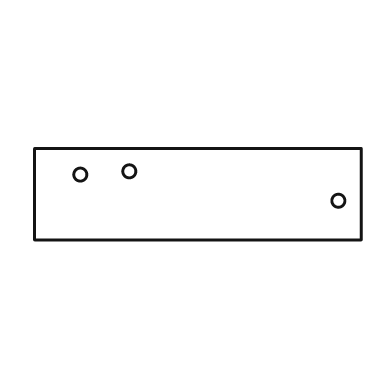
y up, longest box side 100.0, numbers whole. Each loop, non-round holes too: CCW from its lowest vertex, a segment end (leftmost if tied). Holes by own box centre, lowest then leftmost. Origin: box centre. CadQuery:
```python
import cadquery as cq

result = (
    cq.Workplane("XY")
    .moveTo(-50.0, -14.0)
    .lineTo(50.0, -14.0)
    .lineTo(50.0, 14.0)
    .lineTo(-50.0, 14.0)
    .close()
    .moveTo(43.0, -2.0)
    .circle(2.0)
    .moveTo(-36.0, 6.0)
    .circle(2.0)
    .moveTo(-21.0, 7.0)
    .circle(2.0)
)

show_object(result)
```